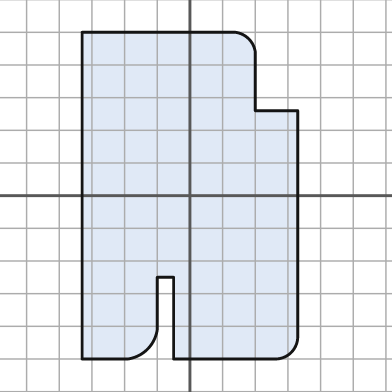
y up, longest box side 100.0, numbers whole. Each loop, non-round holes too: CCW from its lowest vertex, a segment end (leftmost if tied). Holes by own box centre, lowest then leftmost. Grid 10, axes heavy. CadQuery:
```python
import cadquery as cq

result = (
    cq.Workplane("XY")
    .moveTo(-33.0, -50.0)
    .lineTo(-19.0, -50.0)
    .threePointArc((-13.0, -47.0), (-10.0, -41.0))
    .lineTo(-10.0, -25.0)
    .lineTo(-5.0, -25.0)
    .lineTo(-5.0, -50.0)
    .lineTo(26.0, -50.0)
    .threePointArc((31.0, -48.0), (33.0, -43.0))
    .lineTo(33.0, 26.0)
    .lineTo(20.0, 26.0)
    .lineTo(20.0, 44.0)
    .threePointArc((18.0, 48.0), (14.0, 50.0))
    .lineTo(-33.0, 50.0)
    .close()
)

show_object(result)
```